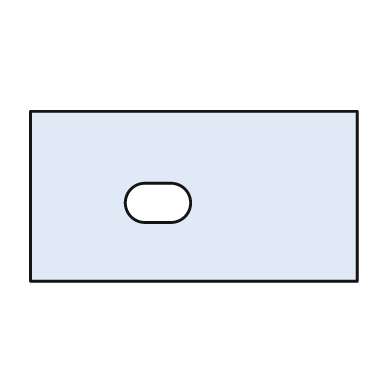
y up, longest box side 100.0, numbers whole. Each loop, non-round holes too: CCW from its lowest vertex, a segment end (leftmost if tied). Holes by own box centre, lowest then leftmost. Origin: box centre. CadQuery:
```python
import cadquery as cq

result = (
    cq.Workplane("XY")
    .moveTo(-50.0, -26.0)
    .lineTo(50.0, -26.0)
    .lineTo(50.0, 26.0)
    .lineTo(-50.0, 26.0)
    .close()
    .moveTo(-15.0, -8.0)
    .lineTo(-7.0, -8.0)
    .threePointArc((-1.0, -2.0), (-7.0, 4.0))
    .lineTo(-15.0, 4.0)
    .threePointArc((-21.0, -2.0), (-15.0, -8.0))
    .close()
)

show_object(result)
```